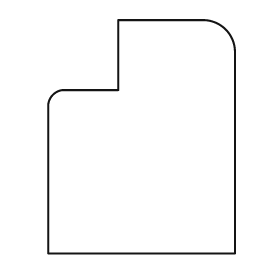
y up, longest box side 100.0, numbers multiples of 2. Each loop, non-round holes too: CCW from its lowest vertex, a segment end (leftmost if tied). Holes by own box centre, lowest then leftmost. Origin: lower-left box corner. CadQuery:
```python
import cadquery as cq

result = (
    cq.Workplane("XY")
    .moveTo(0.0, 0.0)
    .lineTo(80.0, 0.0)
    .lineTo(80.0, 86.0)
    .threePointArc((76.0, 96.0), (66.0, 100.0))
    .lineTo(30.0, 100.0)
    .lineTo(30.0, 70.0)
    .lineTo(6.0, 70.0)
    .threePointArc((2.0, 68.0), (0.0, 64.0))
    .close()
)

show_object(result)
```